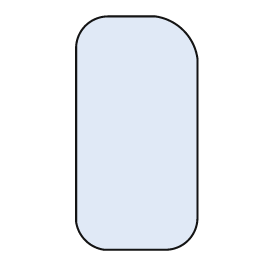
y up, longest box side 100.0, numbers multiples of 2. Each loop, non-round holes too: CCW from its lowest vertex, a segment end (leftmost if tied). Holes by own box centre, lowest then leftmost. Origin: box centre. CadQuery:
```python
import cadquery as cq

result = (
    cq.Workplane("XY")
    .moveTo(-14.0, -50.0)
    .lineTo(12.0, -50.0)
    .threePointArc((22.0, -46.0), (26.0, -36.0))
    .lineTo(26.0, 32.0)
    .threePointArc((20.0, 44.0), (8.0, 50.0))
    .lineTo(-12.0, 50.0)
    .threePointArc((-22.0, 46.0), (-26.0, 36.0))
    .lineTo(-26.0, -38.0)
    .threePointArc((-22.0, -46.0), (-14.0, -50.0))
    .close()
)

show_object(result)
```